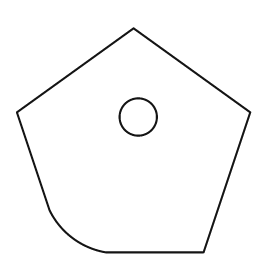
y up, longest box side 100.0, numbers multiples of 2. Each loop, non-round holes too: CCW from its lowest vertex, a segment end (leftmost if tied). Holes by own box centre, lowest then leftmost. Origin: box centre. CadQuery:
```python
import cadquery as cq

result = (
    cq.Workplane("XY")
    .moveTo(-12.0, -48.0)
    .lineTo(30.0, -48.0)
    .lineTo(50.0, 12.0)
    .lineTo(0.0, 48.0)
    .lineTo(-50.0, 12.0)
    .lineTo(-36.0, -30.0)
    .threePointArc((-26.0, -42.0), (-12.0, -48.0))
    .close()
    .moveTo(2.0, 10.0)
    .circle(8.0)
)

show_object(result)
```